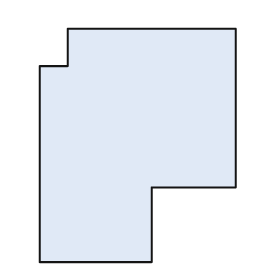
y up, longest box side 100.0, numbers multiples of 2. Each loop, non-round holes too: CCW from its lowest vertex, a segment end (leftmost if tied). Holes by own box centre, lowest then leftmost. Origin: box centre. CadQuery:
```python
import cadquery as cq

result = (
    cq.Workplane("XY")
    .moveTo(-42.0, -50.0)
    .lineTo(6.0, -50.0)
    .lineTo(6.0, -18.0)
    .lineTo(42.0, -18.0)
    .lineTo(42.0, 50.0)
    .lineTo(-30.0, 50.0)
    .lineTo(-30.0, 34.0)
    .lineTo(-42.0, 34.0)
    .close()
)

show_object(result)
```